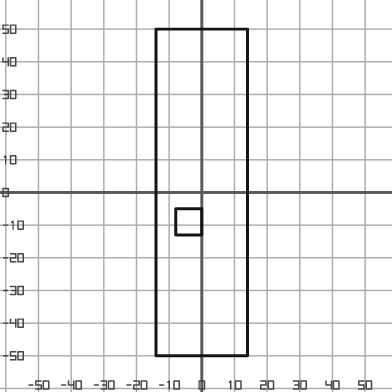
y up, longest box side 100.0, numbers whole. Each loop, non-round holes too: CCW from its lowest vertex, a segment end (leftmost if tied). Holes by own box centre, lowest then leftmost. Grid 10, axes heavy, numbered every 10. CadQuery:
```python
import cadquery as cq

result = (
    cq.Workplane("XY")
    .moveTo(-14.0, -50.0)
    .lineTo(14.0, -50.0)
    .lineTo(14.0, 50.0)
    .lineTo(-14.0, 50.0)
    .close()
    .moveTo(-8.0, -13.0)
    .lineTo(0.0, -13.0)
    .lineTo(0.0, -5.0)
    .lineTo(-8.0, -5.0)
    .close()
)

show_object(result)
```